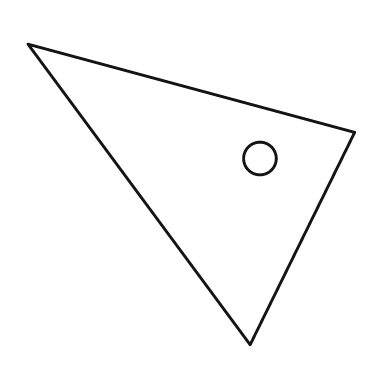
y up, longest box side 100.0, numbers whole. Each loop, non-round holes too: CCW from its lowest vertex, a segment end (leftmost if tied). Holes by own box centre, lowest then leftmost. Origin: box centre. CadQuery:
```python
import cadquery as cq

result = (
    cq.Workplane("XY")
    .moveTo(18.0, -46.0)
    .lineTo(50.0, 19.0)
    .lineTo(-50.0, 46.0)
    .close()
    .moveTo(21.0, 11.0)
    .circle(5.0)
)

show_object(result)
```